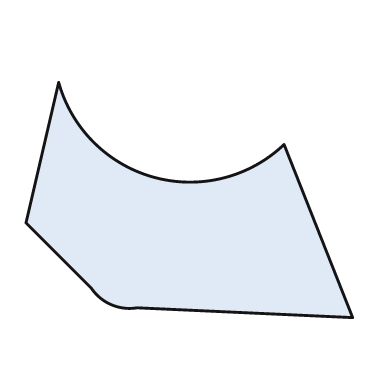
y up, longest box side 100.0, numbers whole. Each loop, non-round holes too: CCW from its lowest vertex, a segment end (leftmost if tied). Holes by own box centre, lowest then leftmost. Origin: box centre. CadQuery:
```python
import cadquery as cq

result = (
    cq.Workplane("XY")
    .moveTo(50.0, -36.0)
    .lineTo(29.0, 17.0)
    .threePointArc((-11.0, 7.0), (-40.0, 36.0))
    .lineTo(-50.0, -7.0)
    .lineTo(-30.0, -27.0)
    .threePointArc((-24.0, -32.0), (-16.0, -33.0))
    .close()
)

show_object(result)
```